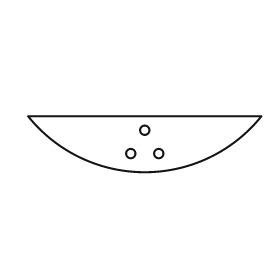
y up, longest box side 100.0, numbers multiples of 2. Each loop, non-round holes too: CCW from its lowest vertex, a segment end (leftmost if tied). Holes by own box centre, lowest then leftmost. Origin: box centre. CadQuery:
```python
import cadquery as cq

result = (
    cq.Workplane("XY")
    .moveTo(-50.0, 12.0)
    .threePointArc((0.0, -12.0), (50.0, 12.0))
    .close()
    .moveTo(-6.0, -4.0)
    .circle(2.0)
    .moveTo(6.0, -4.0)
    .circle(2.0)
    .moveTo(0.0, 6.0)
    .circle(2.0)
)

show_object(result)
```